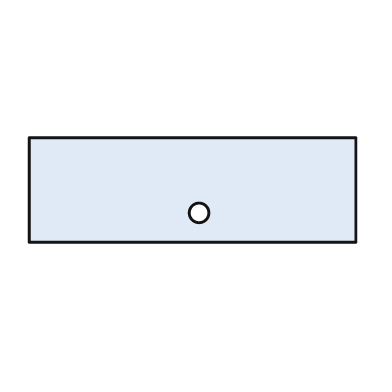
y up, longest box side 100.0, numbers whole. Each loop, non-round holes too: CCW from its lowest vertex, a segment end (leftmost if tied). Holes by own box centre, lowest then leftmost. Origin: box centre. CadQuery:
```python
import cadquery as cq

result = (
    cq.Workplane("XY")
    .moveTo(-50.0, -16.0)
    .lineTo(50.0, -16.0)
    .lineTo(50.0, 16.0)
    .lineTo(-50.0, 16.0)
    .close()
    .moveTo(2.0, -7.0)
    .circle(3.0)
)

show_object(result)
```